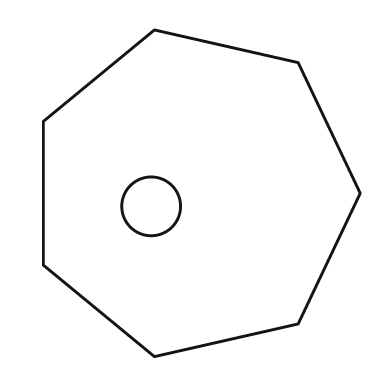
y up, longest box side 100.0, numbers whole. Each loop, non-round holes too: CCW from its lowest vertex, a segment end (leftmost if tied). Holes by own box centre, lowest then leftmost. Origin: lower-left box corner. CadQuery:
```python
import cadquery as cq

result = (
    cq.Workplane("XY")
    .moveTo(34.0, 0.0)
    .lineTo(78.0, 10.0)
    .lineTo(97.0, 50.0)
    .lineTo(78.0, 90.0)
    .lineTo(34.0, 100.0)
    .lineTo(0.0, 72.0)
    .lineTo(0.0, 28.0)
    .close()
    .moveTo(33.0, 46.0)
    .circle(9.0)
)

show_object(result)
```